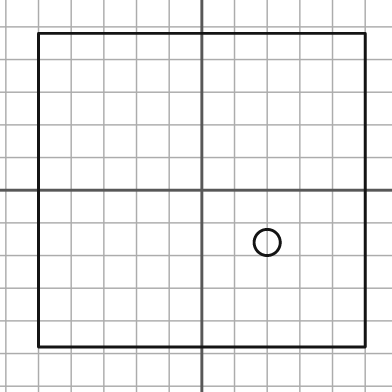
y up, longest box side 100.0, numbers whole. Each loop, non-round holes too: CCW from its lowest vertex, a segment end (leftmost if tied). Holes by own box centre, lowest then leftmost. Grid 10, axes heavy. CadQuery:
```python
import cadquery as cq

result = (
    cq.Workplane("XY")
    .moveTo(-50.0, -48.0)
    .lineTo(50.0, -48.0)
    .lineTo(50.0, 48.0)
    .lineTo(-50.0, 48.0)
    .close()
    .moveTo(20.0, -16.0)
    .circle(4.0)
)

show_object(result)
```